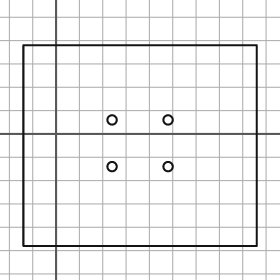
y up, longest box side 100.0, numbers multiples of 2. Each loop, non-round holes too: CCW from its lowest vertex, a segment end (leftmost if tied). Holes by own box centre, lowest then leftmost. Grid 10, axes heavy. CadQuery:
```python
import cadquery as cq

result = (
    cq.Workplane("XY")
    .moveTo(-14.0, -48.0)
    .lineTo(86.0, -48.0)
    .lineTo(86.0, 38.0)
    .lineTo(-14.0, 38.0)
    .close()
    .moveTo(24.0, -14.0)
    .circle(2.0)
    .moveTo(48.0, -14.0)
    .circle(2.0)
    .moveTo(24.0, 6.0)
    .circle(2.0)
    .moveTo(48.0, 6.0)
    .circle(2.0)
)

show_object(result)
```